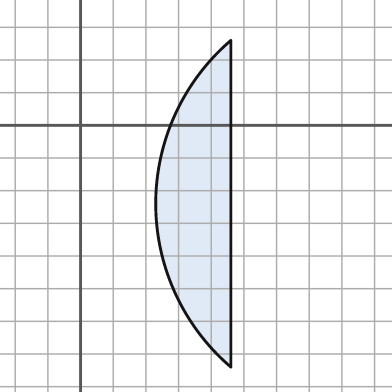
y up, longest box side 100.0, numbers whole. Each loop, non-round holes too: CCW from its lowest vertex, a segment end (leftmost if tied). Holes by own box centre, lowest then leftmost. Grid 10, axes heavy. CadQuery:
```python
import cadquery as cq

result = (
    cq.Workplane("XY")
    .moveTo(46.0, -74.0)
    .lineTo(46.0, 26.0)
    .threePointArc((23.0, -24.0), (46.0, -74.0))
    .close()
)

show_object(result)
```